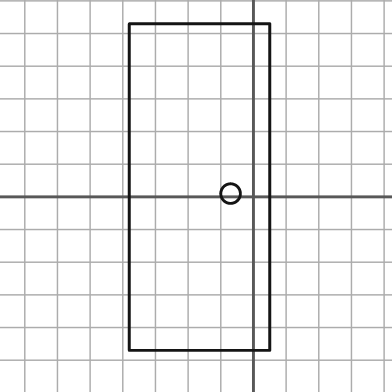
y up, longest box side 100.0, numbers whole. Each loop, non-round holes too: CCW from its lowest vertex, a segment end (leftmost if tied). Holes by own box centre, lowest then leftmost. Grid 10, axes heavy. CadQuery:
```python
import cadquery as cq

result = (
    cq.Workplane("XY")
    .moveTo(-38.0, -47.0)
    .lineTo(5.0, -47.0)
    .lineTo(5.0, 53.0)
    .lineTo(-38.0, 53.0)
    .close()
    .moveTo(-7.0, 1.0)
    .circle(3.0)
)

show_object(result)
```